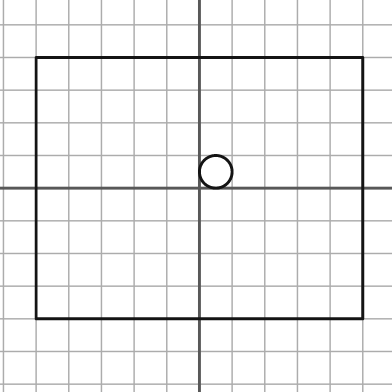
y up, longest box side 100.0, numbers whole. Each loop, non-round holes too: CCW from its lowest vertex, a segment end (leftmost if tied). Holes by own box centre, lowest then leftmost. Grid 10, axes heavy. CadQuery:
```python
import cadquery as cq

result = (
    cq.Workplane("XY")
    .moveTo(-50.0, -40.0)
    .lineTo(50.0, -40.0)
    .lineTo(50.0, 40.0)
    .lineTo(-50.0, 40.0)
    .close()
    .moveTo(5.0, 5.0)
    .circle(5.0)
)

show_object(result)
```